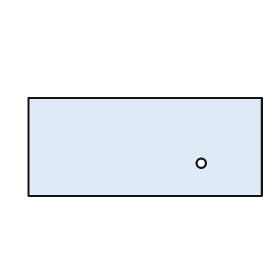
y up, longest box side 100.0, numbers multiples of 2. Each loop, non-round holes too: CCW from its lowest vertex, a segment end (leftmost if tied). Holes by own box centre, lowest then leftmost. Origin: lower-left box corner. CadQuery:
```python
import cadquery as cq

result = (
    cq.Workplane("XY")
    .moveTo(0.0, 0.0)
    .lineTo(100.0, 0.0)
    .lineTo(100.0, 42.0)
    .lineTo(0.0, 42.0)
    .close()
    .moveTo(74.0, 14.0)
    .circle(2.0)
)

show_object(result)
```